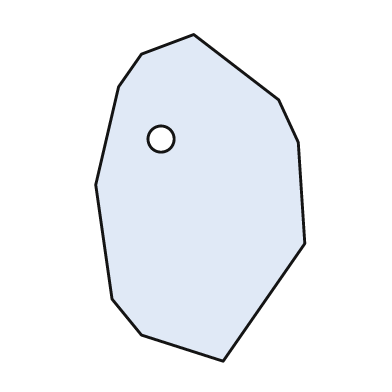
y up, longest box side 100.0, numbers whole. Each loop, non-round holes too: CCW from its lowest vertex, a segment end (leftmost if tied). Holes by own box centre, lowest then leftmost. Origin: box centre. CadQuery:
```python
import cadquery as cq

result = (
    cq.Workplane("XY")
    .moveTo(7.0, -50.0)
    .lineTo(32.0, -14.0)
    .lineTo(30.0, 17.0)
    .lineTo(24.0, 30.0)
    .lineTo(-2.0, 50.0)
    .lineTo(-18.0, 44.0)
    .lineTo(-25.0, 34.0)
    .lineTo(-32.0, 4.0)
    .lineTo(-27.0, -31.0)
    .lineTo(-18.0, -42.0)
    .close()
    .moveTo(-12.0, 18.0)
    .circle(4.0)
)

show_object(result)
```